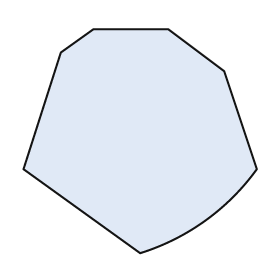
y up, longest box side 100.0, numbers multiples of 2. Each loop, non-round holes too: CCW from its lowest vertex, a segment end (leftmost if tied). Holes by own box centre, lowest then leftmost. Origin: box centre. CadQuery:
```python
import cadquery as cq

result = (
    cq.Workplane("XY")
    .moveTo(0.0, -48.0)
    .threePointArc((28.0, -34.0), (50.0, -12.0))
    .lineTo(36.0, 30.0)
    .lineTo(12.0, 48.0)
    .lineTo(-20.0, 48.0)
    .lineTo(-34.0, 38.0)
    .lineTo(-50.0, -12.0)
    .close()
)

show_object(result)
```